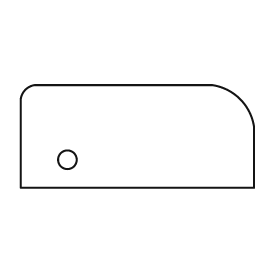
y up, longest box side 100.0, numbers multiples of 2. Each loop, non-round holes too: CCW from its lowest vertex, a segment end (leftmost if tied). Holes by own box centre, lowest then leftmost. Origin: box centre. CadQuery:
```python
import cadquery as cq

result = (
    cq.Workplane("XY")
    .moveTo(-50.0, -22.0)
    .lineTo(50.0, -22.0)
    .lineTo(50.0, 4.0)
    .threePointArc((44.0, 16.0), (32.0, 22.0))
    .lineTo(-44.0, 22.0)
    .threePointArc((-48.0, 20.0), (-50.0, 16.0))
    .close()
    .moveTo(-30.0, -10.0)
    .circle(4.0)
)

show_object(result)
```